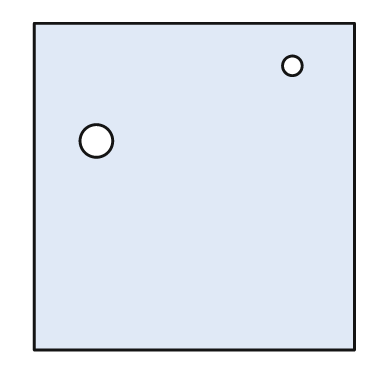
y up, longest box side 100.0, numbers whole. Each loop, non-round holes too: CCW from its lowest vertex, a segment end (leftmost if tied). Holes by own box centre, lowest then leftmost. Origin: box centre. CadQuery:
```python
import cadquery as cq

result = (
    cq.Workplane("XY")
    .moveTo(-49.0, -50.0)
    .lineTo(49.0, -50.0)
    .lineTo(49.0, 50.0)
    .lineTo(-49.0, 50.0)
    .close()
    .moveTo(-30.0, 14.0)
    .circle(5.0)
    .moveTo(30.0, 37.0)
    .circle(3.0)
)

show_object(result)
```